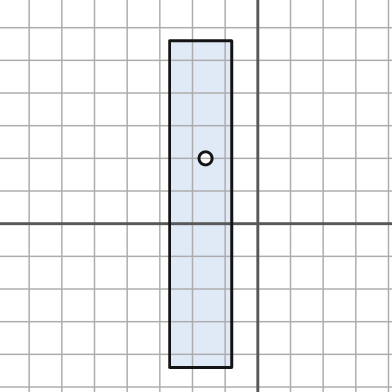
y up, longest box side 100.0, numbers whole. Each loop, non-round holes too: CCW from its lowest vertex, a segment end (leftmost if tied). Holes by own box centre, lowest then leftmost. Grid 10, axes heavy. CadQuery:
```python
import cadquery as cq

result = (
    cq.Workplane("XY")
    .moveTo(-27.0, -44.0)
    .lineTo(-8.0, -44.0)
    .lineTo(-8.0, 56.0)
    .lineTo(-27.0, 56.0)
    .close()
    .moveTo(-16.0, 20.0)
    .circle(2.0)
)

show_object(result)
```